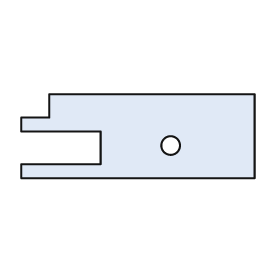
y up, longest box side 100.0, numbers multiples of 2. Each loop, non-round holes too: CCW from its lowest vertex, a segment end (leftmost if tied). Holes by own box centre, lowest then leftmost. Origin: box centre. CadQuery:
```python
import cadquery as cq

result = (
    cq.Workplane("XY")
    .moveTo(-50.0, -18.0)
    .lineTo(50.0, -18.0)
    .lineTo(50.0, 18.0)
    .lineTo(-38.0, 18.0)
    .lineTo(-38.0, 8.0)
    .lineTo(-50.0, 8.0)
    .lineTo(-50.0, 2.0)
    .lineTo(-16.0, 2.0)
    .lineTo(-16.0, -12.0)
    .lineTo(-50.0, -12.0)
    .close()
    .moveTo(14.0, -4.0)
    .circle(4.0)
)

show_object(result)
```